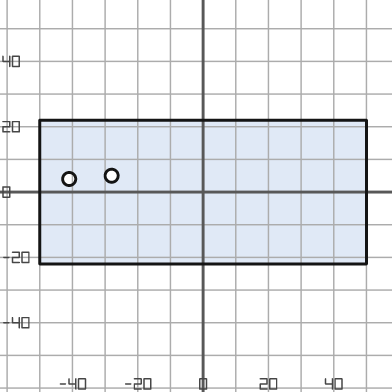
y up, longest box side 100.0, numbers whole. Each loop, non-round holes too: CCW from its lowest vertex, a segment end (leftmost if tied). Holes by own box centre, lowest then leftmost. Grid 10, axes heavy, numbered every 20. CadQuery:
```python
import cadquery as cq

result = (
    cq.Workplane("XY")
    .moveTo(-50.0, -22.0)
    .lineTo(50.0, -22.0)
    .lineTo(50.0, 22.0)
    .lineTo(-50.0, 22.0)
    .close()
    .moveTo(-41.0, 4.0)
    .circle(2.0)
    .moveTo(-28.0, 5.0)
    .circle(2.0)
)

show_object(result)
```